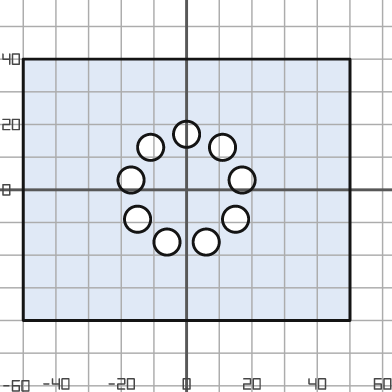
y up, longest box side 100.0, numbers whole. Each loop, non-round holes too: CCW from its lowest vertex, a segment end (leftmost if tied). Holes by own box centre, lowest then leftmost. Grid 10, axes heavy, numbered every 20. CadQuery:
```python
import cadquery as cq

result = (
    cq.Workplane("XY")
    .moveTo(-50.0, -40.0)
    .lineTo(50.0, -40.0)
    .lineTo(50.0, 40.0)
    .lineTo(-50.0, 40.0)
    .close()
    .moveTo(-6.0, -16.0)
    .circle(4.0)
    .moveTo(6.0, -16.0)
    .circle(4.0)
    .moveTo(-15.0, -9.0)
    .circle(4.0)
    .moveTo(15.0, -9.0)
    .circle(4.0)
    .moveTo(-17.0, 3.0)
    .circle(4.0)
    .moveTo(17.0, 3.0)
    .circle(4.0)
    .moveTo(-11.0, 13.0)
    .circle(4.0)
    .moveTo(11.0, 13.0)
    .circle(4.0)
    .moveTo(0.0, 17.0)
    .circle(4.0)
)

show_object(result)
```